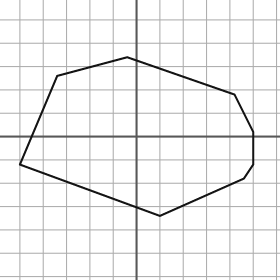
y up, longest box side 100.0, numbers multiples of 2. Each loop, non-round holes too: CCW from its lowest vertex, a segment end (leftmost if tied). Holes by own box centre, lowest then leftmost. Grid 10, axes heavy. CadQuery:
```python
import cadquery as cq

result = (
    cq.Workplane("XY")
    .moveTo(10.0, -34.0)
    .lineTo(46.0, -18.0)
    .lineTo(50.0, -12.0)
    .lineTo(50.0, 2.0)
    .lineTo(42.0, 18.0)
    .lineTo(-4.0, 34.0)
    .lineTo(-34.0, 26.0)
    .lineTo(-50.0, -12.0)
    .close()
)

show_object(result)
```